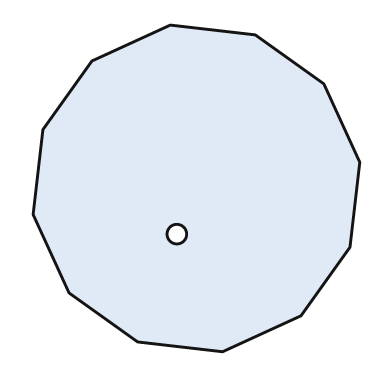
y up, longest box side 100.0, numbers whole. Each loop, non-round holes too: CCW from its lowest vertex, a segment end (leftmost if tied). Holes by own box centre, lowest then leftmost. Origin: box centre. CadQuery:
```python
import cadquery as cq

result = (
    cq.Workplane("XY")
    .moveTo(8.0, -50.0)
    .lineTo(32.0, -39.0)
    .lineTo(47.0, -18.0)
    .lineTo(50.0, 8.0)
    .lineTo(39.0, 32.0)
    .lineTo(18.0, 47.0)
    .lineTo(-8.0, 50.0)
    .lineTo(-32.0, 39.0)
    .lineTo(-47.0, 18.0)
    .lineTo(-50.0, -8.0)
    .lineTo(-39.0, -32.0)
    .lineTo(-18.0, -47.0)
    .close()
    .moveTo(-6.0, -14.0)
    .circle(3.0)
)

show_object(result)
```